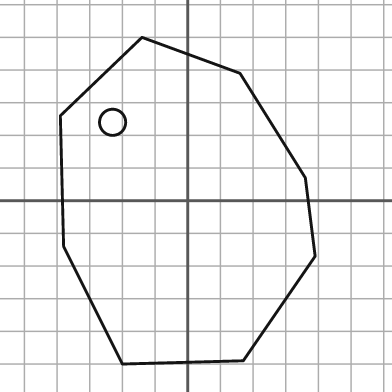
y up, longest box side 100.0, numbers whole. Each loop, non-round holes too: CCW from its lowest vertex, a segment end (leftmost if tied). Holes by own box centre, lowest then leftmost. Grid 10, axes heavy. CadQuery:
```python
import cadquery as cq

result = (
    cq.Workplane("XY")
    .moveTo(-20.0, -50.0)
    .lineTo(17.0, -49.0)
    .lineTo(39.0, -17.0)
    .lineTo(36.0, 7.0)
    .lineTo(16.0, 39.0)
    .lineTo(-14.0, 50.0)
    .lineTo(-39.0, 26.0)
    .lineTo(-38.0, -14.0)
    .close()
    .moveTo(-23.0, 24.0)
    .circle(4.0)
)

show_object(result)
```